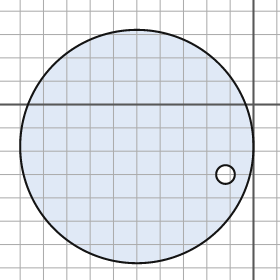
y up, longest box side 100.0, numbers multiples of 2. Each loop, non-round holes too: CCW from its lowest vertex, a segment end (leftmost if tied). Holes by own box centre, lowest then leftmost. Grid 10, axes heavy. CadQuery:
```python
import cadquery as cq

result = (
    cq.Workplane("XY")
    .moveTo(-50.0, -18.0)
    .circle(50.0)
    .moveTo(-12.0, -30.0)
    .circle(4.0)
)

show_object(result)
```